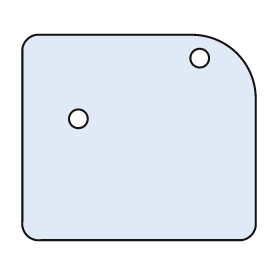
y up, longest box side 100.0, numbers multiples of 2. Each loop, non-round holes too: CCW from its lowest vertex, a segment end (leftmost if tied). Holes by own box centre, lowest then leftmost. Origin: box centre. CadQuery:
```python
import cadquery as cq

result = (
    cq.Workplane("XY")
    .moveTo(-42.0, -44.0)
    .lineTo(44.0, -44.0)
    .threePointArc((48.0, -42.0), (50.0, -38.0))
    .lineTo(50.0, 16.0)
    .threePointArc((42.0, 36.0), (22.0, 44.0))
    .lineTo(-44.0, 44.0)
    .threePointArc((-48.0, 42.0), (-50.0, 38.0))
    .lineTo(-50.0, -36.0)
    .threePointArc((-48.0, -42.0), (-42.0, -44.0))
    .close()
    .moveTo(-26.0, 8.0)
    .circle(4.0)
    .moveTo(26.0, 34.0)
    .circle(4.0)
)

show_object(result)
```